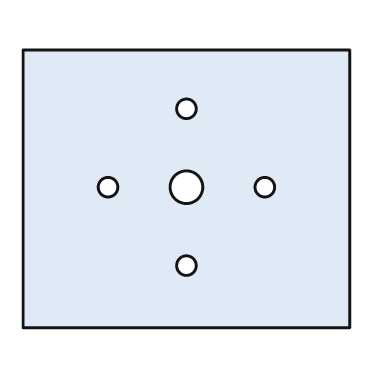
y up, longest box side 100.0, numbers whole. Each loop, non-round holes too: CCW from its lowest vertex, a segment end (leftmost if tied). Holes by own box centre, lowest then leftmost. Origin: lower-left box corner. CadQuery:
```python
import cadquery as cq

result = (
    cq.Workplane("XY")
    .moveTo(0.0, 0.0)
    .lineTo(100.0, 0.0)
    .lineTo(100.0, 85.0)
    .lineTo(0.0, 85.0)
    .close()
    .moveTo(50.0, 19.0)
    .circle(3.0)
    .moveTo(26.0, 43.0)
    .circle(3.0)
    .moveTo(50.0, 43.0)
    .circle(5.0)
    .moveTo(74.0, 43.0)
    .circle(3.0)
    .moveTo(50.0, 67.0)
    .circle(3.0)
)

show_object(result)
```